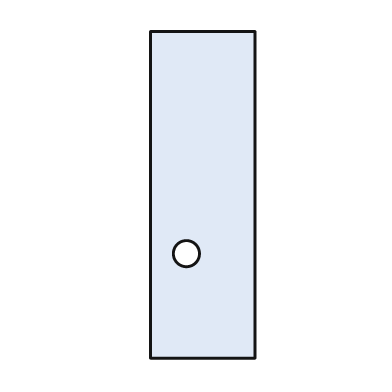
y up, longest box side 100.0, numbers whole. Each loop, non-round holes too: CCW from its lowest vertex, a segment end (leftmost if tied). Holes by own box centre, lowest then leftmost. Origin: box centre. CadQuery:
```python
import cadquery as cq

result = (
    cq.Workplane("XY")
    .moveTo(-16.0, -50.0)
    .lineTo(16.0, -50.0)
    .lineTo(16.0, 50.0)
    .lineTo(-16.0, 50.0)
    .close()
    .moveTo(-5.0, -18.0)
    .circle(4.0)
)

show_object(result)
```